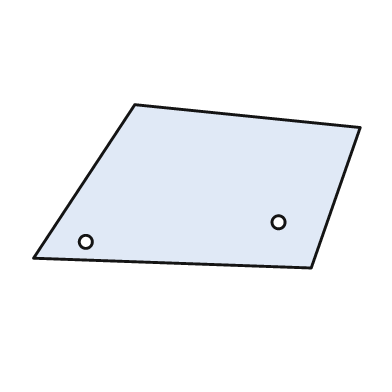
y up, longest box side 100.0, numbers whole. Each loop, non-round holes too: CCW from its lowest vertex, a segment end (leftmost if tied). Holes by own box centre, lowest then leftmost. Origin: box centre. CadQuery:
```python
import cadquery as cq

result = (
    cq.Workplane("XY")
    .moveTo(35.0, -25.0)
    .lineTo(50.0, 18.0)
    .lineTo(-19.0, 25.0)
    .lineTo(-50.0, -22.0)
    .close()
    .moveTo(-34.0, -17.0)
    .circle(2.0)
    .moveTo(25.0, -11.0)
    .circle(2.0)
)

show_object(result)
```